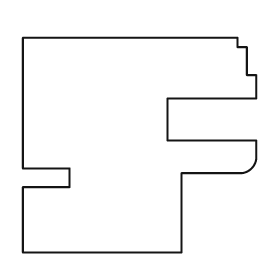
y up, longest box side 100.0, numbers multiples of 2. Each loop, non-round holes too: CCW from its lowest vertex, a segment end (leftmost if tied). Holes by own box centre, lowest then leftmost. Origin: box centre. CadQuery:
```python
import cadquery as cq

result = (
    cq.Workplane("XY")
    .moveTo(-50.0, -46.0)
    .lineTo(18.0, -46.0)
    .lineTo(18.0, -12.0)
    .lineTo(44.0, -12.0)
    .threePointArc((48.0, -10.0), (50.0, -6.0))
    .lineTo(50.0, 2.0)
    .lineTo(12.0, 2.0)
    .lineTo(12.0, 20.0)
    .lineTo(50.0, 20.0)
    .lineTo(50.0, 30.0)
    .lineTo(46.0, 30.0)
    .lineTo(46.0, 42.0)
    .lineTo(42.0, 42.0)
    .lineTo(42.0, 46.0)
    .lineTo(-50.0, 46.0)
    .lineTo(-50.0, -10.0)
    .lineTo(-30.0, -10.0)
    .lineTo(-30.0, -18.0)
    .lineTo(-50.0, -18.0)
    .close()
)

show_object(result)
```